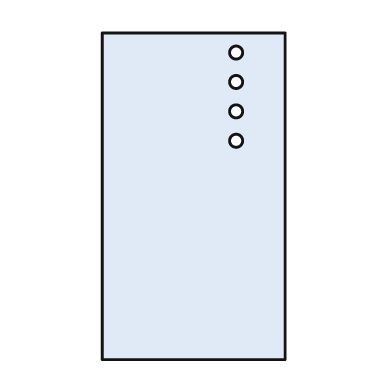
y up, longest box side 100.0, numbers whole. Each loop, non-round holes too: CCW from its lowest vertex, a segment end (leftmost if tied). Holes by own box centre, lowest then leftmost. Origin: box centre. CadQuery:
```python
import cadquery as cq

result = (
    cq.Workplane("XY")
    .moveTo(-28.0, -50.0)
    .lineTo(28.0, -50.0)
    .lineTo(28.0, 50.0)
    .lineTo(-28.0, 50.0)
    .close()
    .moveTo(13.0, 17.0)
    .circle(2.0)
    .moveTo(13.0, 26.0)
    .circle(2.0)
    .moveTo(13.0, 35.0)
    .circle(2.0)
    .moveTo(13.0, 44.0)
    .circle(2.0)
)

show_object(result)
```